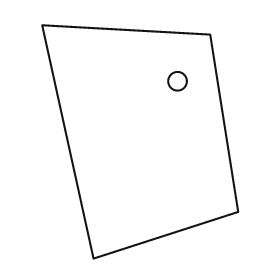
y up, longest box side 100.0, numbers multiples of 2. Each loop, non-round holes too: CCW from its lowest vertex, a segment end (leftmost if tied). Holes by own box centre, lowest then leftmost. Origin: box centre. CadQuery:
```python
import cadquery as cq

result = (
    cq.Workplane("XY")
    .moveTo(-20.0, -50.0)
    .lineTo(42.0, -30.0)
    .lineTo(30.0, 46.0)
    .lineTo(-42.0, 50.0)
    .close()
    .moveTo(16.0, 26.0)
    .circle(4.0)
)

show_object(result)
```